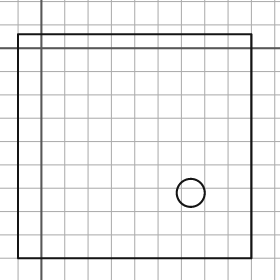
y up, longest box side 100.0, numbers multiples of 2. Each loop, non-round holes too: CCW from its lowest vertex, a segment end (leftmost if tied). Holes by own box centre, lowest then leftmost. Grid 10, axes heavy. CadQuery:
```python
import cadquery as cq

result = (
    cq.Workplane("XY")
    .moveTo(-10.0, -90.0)
    .lineTo(90.0, -90.0)
    .lineTo(90.0, 6.0)
    .lineTo(-10.0, 6.0)
    .close()
    .moveTo(64.0, -62.0)
    .circle(6.0)
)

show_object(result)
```